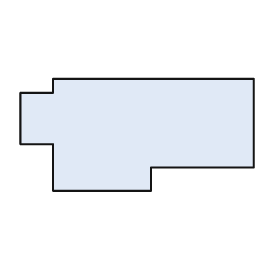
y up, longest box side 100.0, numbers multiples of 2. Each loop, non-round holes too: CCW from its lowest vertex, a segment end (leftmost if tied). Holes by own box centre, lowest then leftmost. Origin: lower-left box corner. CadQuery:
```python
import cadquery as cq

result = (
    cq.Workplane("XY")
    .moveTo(14.0, 0.0)
    .lineTo(56.0, 0.0)
    .lineTo(56.0, 10.0)
    .lineTo(100.0, 10.0)
    .lineTo(100.0, 48.0)
    .lineTo(14.0, 48.0)
    .lineTo(14.0, 42.0)
    .lineTo(0.0, 42.0)
    .lineTo(0.0, 20.0)
    .lineTo(14.0, 20.0)
    .close()
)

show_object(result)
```